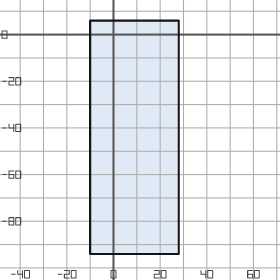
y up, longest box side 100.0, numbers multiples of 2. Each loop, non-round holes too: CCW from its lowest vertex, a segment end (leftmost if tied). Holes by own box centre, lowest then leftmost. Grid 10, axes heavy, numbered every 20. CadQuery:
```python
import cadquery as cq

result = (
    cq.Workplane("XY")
    .moveTo(-10.0, -94.0)
    .lineTo(28.0, -94.0)
    .lineTo(28.0, 6.0)
    .lineTo(-10.0, 6.0)
    .close()
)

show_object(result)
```